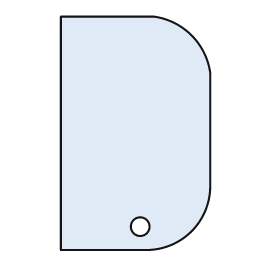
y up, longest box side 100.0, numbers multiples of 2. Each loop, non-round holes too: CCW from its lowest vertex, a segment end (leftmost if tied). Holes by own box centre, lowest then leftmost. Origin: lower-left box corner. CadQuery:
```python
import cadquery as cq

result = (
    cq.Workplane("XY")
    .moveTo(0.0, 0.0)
    .lineTo(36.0, 0.0)
    .threePointArc((56.0, 8.0), (64.0, 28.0))
    .lineTo(64.0, 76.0)
    .threePointArc((56.0, 92.0), (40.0, 100.0))
    .lineTo(0.0, 100.0)
    .close()
    .moveTo(34.0, 10.0)
    .circle(4.0)
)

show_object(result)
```